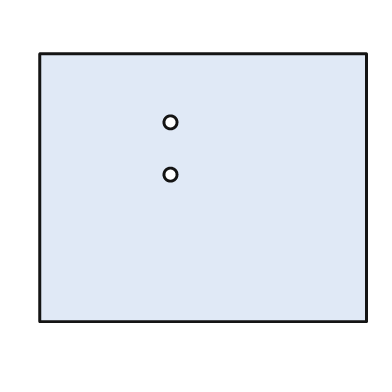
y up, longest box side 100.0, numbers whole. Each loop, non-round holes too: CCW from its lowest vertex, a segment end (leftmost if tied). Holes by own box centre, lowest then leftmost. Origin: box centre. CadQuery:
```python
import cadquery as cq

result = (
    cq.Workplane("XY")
    .moveTo(-50.0, -41.0)
    .lineTo(50.0, -41.0)
    .lineTo(50.0, 41.0)
    .lineTo(-50.0, 41.0)
    .close()
    .moveTo(-10.0, 4.0)
    .circle(2.0)
    .moveTo(-10.0, 20.0)
    .circle(2.0)
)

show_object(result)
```